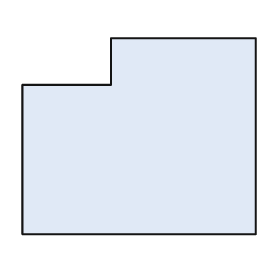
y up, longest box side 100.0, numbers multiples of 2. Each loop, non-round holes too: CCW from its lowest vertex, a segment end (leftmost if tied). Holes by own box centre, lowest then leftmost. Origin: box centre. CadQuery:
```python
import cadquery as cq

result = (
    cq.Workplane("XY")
    .moveTo(-50.0, -42.0)
    .lineTo(50.0, -42.0)
    .lineTo(50.0, 42.0)
    .lineTo(-12.0, 42.0)
    .lineTo(-12.0, 22.0)
    .lineTo(-50.0, 22.0)
    .close()
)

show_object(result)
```